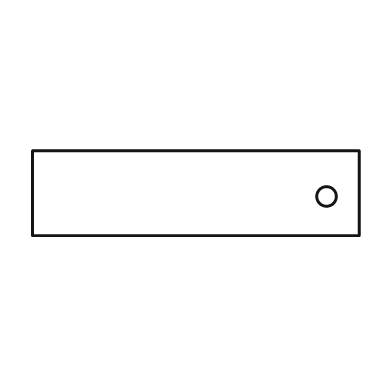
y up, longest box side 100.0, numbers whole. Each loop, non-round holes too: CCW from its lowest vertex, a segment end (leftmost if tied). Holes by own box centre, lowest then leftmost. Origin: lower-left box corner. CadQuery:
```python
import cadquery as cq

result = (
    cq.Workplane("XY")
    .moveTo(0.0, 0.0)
    .lineTo(100.0, 0.0)
    .lineTo(100.0, 26.0)
    .lineTo(0.0, 26.0)
    .close()
    .moveTo(90.0, 12.0)
    .circle(3.0)
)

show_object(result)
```